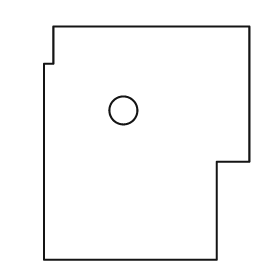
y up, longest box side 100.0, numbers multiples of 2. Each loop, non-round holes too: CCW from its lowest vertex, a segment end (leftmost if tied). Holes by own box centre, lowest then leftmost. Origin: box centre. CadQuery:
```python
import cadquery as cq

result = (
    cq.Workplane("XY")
    .moveTo(-44.0, -50.0)
    .lineTo(30.0, -50.0)
    .lineTo(30.0, -8.0)
    .lineTo(44.0, -8.0)
    .lineTo(44.0, 50.0)
    .lineTo(-40.0, 50.0)
    .lineTo(-40.0, 34.0)
    .lineTo(-44.0, 34.0)
    .close()
    .moveTo(-10.0, 14.0)
    .circle(6.0)
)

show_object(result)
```